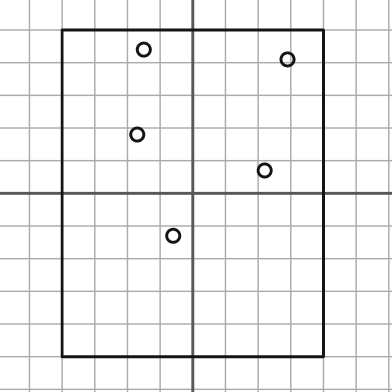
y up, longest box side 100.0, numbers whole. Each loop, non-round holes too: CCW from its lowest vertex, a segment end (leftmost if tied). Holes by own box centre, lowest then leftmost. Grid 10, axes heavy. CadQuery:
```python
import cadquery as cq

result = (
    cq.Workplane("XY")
    .moveTo(-40.0, -50.0)
    .lineTo(40.0, -50.0)
    .lineTo(40.0, 50.0)
    .lineTo(-40.0, 50.0)
    .close()
    .moveTo(-6.0, -13.0)
    .circle(2.0)
    .moveTo(22.0, 7.0)
    .circle(2.0)
    .moveTo(-17.0, 18.0)
    .circle(2.0)
    .moveTo(29.0, 41.0)
    .circle(2.0)
    .moveTo(-15.0, 44.0)
    .circle(2.0)
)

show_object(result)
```